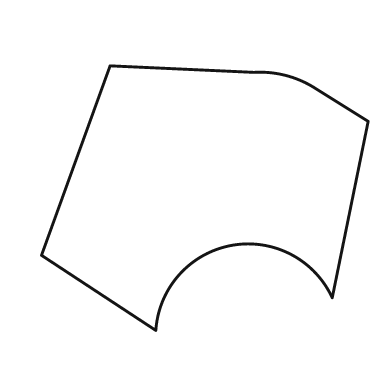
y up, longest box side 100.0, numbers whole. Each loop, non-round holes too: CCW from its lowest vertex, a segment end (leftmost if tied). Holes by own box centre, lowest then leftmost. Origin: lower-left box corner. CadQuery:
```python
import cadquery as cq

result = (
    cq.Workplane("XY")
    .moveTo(35.0, 0.0)
    .threePointArc((58.0, 26.0), (89.0, 10.0))
    .lineTo(100.0, 64.0)
    .lineTo(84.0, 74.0)
    .threePointArc((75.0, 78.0), (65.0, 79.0))
    .lineTo(21.0, 81.0)
    .lineTo(0.0, 23.0)
    .close()
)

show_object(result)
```